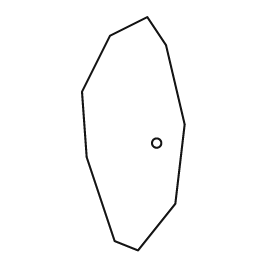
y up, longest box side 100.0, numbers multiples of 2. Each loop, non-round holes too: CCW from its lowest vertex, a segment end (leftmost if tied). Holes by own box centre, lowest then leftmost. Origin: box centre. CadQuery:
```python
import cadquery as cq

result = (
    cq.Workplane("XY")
    .moveTo(2.0, -50.0)
    .lineTo(18.0, -30.0)
    .lineTo(22.0, 4.0)
    .lineTo(14.0, 38.0)
    .lineTo(6.0, 50.0)
    .lineTo(-10.0, 42.0)
    .lineTo(-22.0, 18.0)
    .lineTo(-20.0, -10.0)
    .lineTo(-8.0, -46.0)
    .close()
    .moveTo(10.0, -4.0)
    .circle(2.0)
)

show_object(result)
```